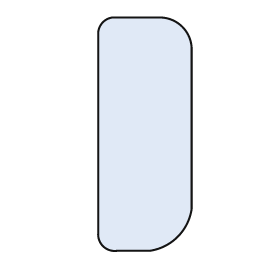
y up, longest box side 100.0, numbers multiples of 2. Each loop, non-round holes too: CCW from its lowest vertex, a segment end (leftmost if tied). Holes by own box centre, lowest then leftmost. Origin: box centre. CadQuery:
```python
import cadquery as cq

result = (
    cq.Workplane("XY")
    .moveTo(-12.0, -50.0)
    .lineTo(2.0, -50.0)
    .threePointArc((14.0, -44.0), (20.0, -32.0))
    .lineTo(20.0, 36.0)
    .threePointArc((16.0, 46.0), (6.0, 50.0))
    .lineTo(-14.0, 50.0)
    .threePointArc((-18.0, 48.0), (-20.0, 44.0))
    .lineTo(-20.0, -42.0)
    .threePointArc((-18.0, -48.0), (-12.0, -50.0))
    .close()
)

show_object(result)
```